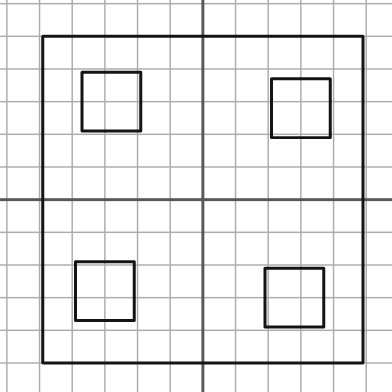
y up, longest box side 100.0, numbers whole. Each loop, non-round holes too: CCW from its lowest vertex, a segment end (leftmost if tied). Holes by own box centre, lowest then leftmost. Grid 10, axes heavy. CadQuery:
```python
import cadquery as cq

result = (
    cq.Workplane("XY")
    .moveTo(-49.0, -50.0)
    .lineTo(49.0, -50.0)
    .lineTo(49.0, 50.0)
    .lineTo(-49.0, 50.0)
    .close()
    .moveTo(19.0, -39.0)
    .lineTo(37.0, -39.0)
    .lineTo(37.0, -21.0)
    .lineTo(19.0, -21.0)
    .close()
    .moveTo(-39.0, -37.0)
    .lineTo(-21.0, -37.0)
    .lineTo(-21.0, -19.0)
    .lineTo(-39.0, -19.0)
    .close()
    .moveTo(21.0, 19.0)
    .lineTo(39.0, 19.0)
    .lineTo(39.0, 37.0)
    .lineTo(21.0, 37.0)
    .close()
    .moveTo(-37.0, 21.0)
    .lineTo(-19.0, 21.0)
    .lineTo(-19.0, 39.0)
    .lineTo(-37.0, 39.0)
    .close()
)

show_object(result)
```